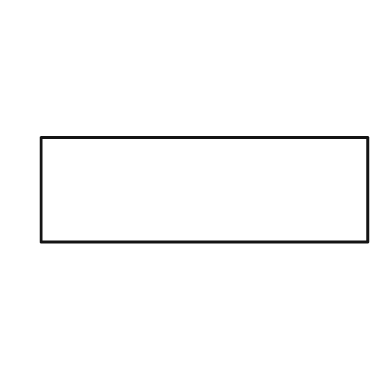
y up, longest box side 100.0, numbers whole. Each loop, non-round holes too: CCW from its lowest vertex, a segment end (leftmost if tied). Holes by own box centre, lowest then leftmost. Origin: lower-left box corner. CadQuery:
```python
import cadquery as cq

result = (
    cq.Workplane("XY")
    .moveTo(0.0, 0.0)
    .lineTo(100.0, 0.0)
    .lineTo(100.0, 32.0)
    .lineTo(0.0, 32.0)
    .close()
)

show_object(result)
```